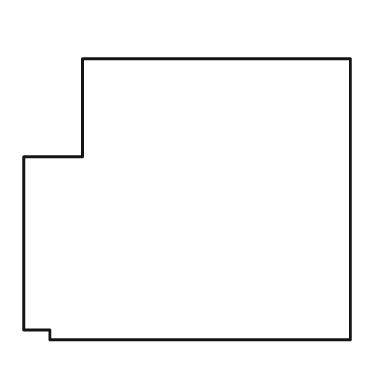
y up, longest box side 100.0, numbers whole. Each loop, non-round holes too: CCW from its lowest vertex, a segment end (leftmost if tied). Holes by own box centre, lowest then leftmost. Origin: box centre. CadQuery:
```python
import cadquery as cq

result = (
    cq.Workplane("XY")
    .moveTo(-42.0, -43.0)
    .lineTo(50.0, -43.0)
    .lineTo(50.0, 43.0)
    .lineTo(-32.0, 43.0)
    .lineTo(-32.0, 13.0)
    .lineTo(-50.0, 13.0)
    .lineTo(-50.0, -40.0)
    .lineTo(-42.0, -40.0)
    .close()
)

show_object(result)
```